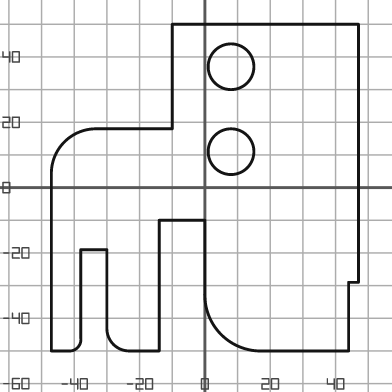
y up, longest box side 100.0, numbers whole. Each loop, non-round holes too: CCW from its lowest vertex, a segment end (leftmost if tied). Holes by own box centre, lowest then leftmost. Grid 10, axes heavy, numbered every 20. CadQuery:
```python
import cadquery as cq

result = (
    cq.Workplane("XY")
    .moveTo(-47.0, -50.0)
    .lineTo(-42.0, -50.0)
    .threePointArc((-39.0, -49.0), (-38.0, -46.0))
    .lineTo(-38.0, -19.0)
    .lineTo(-30.0, -19.0)
    .lineTo(-30.0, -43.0)
    .threePointArc((-28.0, -48.0), (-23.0, -50.0))
    .lineTo(-14.0, -50.0)
    .lineTo(-14.0, -10.0)
    .lineTo(0.0, -10.0)
    .lineTo(0.0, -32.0)
    .threePointArc((5.0, -45.0), (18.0, -50.0))
    .lineTo(44.0, -50.0)
    .lineTo(44.0, -29.0)
    .lineTo(47.0, -29.0)
    .lineTo(47.0, 50.0)
    .lineTo(-10.0, 50.0)
    .lineTo(-10.0, 18.0)
    .lineTo(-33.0, 18.0)
    .threePointArc((-43.0, 14.0), (-47.0, 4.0))
    .close()
    .moveTo(8.0, 11.0)
    .circle(7.0)
    .moveTo(8.0, 37.0)
    .circle(7.0)
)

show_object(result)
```